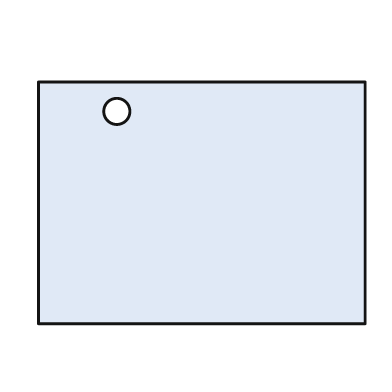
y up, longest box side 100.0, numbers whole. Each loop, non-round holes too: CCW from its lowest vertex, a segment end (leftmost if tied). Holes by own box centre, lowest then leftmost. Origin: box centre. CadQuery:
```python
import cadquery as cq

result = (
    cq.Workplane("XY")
    .moveTo(-50.0, -37.0)
    .lineTo(50.0, -37.0)
    .lineTo(50.0, 37.0)
    .lineTo(-50.0, 37.0)
    .close()
    .moveTo(-26.0, 28.0)
    .circle(4.0)
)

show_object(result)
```